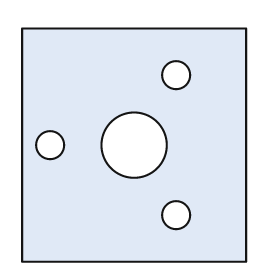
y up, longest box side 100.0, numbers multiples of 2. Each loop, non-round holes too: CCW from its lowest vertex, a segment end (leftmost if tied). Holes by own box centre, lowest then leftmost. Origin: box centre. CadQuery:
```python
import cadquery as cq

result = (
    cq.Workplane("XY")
    .moveTo(-48.0, -50.0)
    .lineTo(48.0, -50.0)
    .lineTo(48.0, 50.0)
    .lineTo(-48.0, 50.0)
    .close()
    .moveTo(18.0, -30.0)
    .circle(6.0)
    .moveTo(-36.0, 0.0)
    .circle(6.0)
    .moveTo(0.0, 0.0)
    .circle(14.0)
    .moveTo(18.0, 30.0)
    .circle(6.0)
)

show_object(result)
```